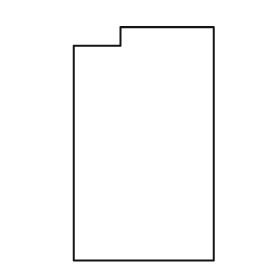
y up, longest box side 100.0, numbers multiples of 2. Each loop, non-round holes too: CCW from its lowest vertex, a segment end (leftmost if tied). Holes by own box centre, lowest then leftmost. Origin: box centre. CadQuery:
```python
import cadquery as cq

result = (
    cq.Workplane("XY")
    .moveTo(-30.0, -50.0)
    .lineTo(30.0, -50.0)
    .lineTo(30.0, 50.0)
    .lineTo(-10.0, 50.0)
    .lineTo(-10.0, 42.0)
    .lineTo(-30.0, 42.0)
    .close()
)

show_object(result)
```